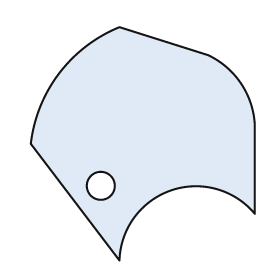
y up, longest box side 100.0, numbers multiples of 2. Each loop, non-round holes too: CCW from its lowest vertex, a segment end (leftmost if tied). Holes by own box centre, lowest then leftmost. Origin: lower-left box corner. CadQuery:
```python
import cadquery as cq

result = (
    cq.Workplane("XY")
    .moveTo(38.0, 0.0)
    .threePointArc((60.0, 30.0), (96.0, 20.0))
    .lineTo(96.0, 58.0)
    .threePointArc((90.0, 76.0), (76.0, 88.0))
    .lineTo(38.0, 100.0)
    .threePointArc((12.0, 80.0), (0.0, 50.0))
    .close()
    .moveTo(30.0, 32.0)
    .circle(6.0)
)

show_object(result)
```